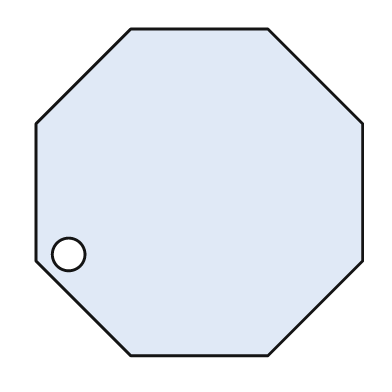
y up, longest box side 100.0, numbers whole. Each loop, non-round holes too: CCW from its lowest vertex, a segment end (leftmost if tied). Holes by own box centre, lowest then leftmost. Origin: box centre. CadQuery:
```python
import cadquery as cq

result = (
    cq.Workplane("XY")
    .moveTo(-21.0, -50.0)
    .lineTo(21.0, -50.0)
    .lineTo(50.0, -21.0)
    .lineTo(50.0, 21.0)
    .lineTo(21.0, 50.0)
    .lineTo(-21.0, 50.0)
    .lineTo(-50.0, 21.0)
    .lineTo(-50.0, -21.0)
    .close()
    .moveTo(-40.0, -19.0)
    .circle(5.0)
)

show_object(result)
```